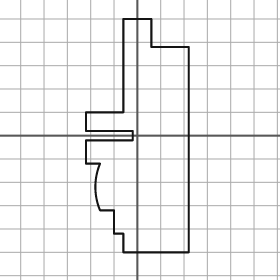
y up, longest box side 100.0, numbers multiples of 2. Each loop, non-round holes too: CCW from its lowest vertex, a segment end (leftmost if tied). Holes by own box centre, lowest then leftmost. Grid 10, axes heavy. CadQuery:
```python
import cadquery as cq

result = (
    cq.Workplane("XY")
    .moveTo(-6.0, -50.0)
    .lineTo(22.0, -50.0)
    .lineTo(22.0, 38.0)
    .lineTo(6.0, 38.0)
    .lineTo(6.0, 50.0)
    .lineTo(-6.0, 50.0)
    .lineTo(-6.0, 10.0)
    .lineTo(-22.0, 10.0)
    .lineTo(-22.0, 2.0)
    .lineTo(-2.0, 2.0)
    .lineTo(-2.0, -2.0)
    .lineTo(-22.0, -2.0)
    .lineTo(-22.0, -12.0)
    .lineTo(-16.0, -12.0)
    .threePointArc((-18.0, -22.0), (-16.0, -32.0))
    .lineTo(-10.0, -32.0)
    .lineTo(-10.0, -42.0)
    .lineTo(-6.0, -42.0)
    .close()
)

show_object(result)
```